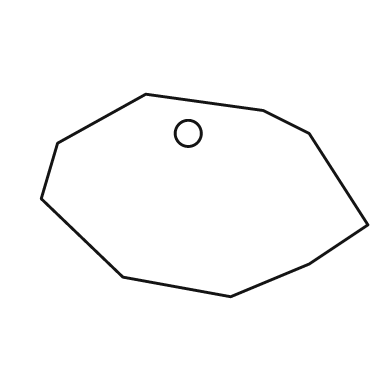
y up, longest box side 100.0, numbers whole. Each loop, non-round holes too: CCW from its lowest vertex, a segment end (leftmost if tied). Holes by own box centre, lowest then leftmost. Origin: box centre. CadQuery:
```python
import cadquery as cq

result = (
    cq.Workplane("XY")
    .moveTo(8.0, -31.0)
    .lineTo(32.0, -21.0)
    .lineTo(50.0, -9.0)
    .lineTo(32.0, 19.0)
    .lineTo(18.0, 26.0)
    .lineTo(-18.0, 31.0)
    .lineTo(-45.0, 16.0)
    .lineTo(-50.0, -1.0)
    .lineTo(-25.0, -25.0)
    .close()
    .moveTo(-5.0, 19.0)
    .circle(4.0)
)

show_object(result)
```